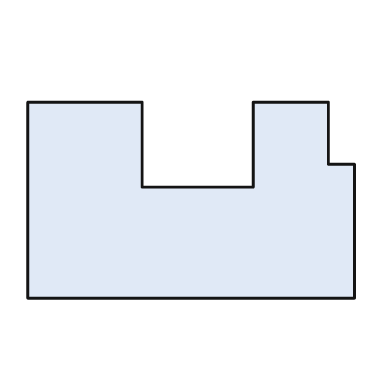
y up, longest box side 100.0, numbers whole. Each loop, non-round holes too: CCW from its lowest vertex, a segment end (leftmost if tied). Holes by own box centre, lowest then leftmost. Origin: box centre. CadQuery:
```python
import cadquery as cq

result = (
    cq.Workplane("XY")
    .moveTo(-50.0, -30.0)
    .lineTo(50.0, -30.0)
    .lineTo(50.0, 11.0)
    .lineTo(42.0, 11.0)
    .lineTo(42.0, 30.0)
    .lineTo(19.0, 30.0)
    .lineTo(19.0, 4.0)
    .lineTo(-15.0, 4.0)
    .lineTo(-15.0, 30.0)
    .lineTo(-50.0, 30.0)
    .close()
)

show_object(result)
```